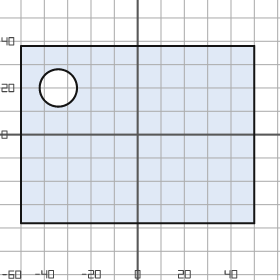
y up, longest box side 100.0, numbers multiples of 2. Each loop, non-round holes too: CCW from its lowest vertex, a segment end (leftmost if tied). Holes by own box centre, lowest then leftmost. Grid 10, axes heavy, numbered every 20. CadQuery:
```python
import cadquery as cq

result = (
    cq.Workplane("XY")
    .moveTo(-50.0, -38.0)
    .lineTo(50.0, -38.0)
    .lineTo(50.0, 38.0)
    .lineTo(-50.0, 38.0)
    .close()
    .moveTo(-34.0, 20.0)
    .circle(8.0)
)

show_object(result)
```